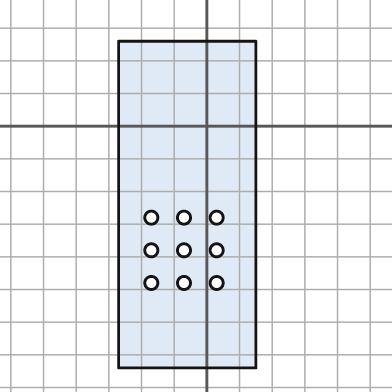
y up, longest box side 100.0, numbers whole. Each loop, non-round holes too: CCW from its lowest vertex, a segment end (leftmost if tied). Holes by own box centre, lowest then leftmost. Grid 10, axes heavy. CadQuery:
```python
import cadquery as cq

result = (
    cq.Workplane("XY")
    .moveTo(-27.0, -74.0)
    .lineTo(15.0, -74.0)
    .lineTo(15.0, 26.0)
    .lineTo(-27.0, 26.0)
    .close()
    .moveTo(-17.0, -48.0)
    .circle(2.0)
    .moveTo(-7.0, -48.0)
    .circle(2.0)
    .moveTo(3.0, -48.0)
    .circle(2.0)
    .moveTo(-17.0, -38.0)
    .circle(2.0)
    .moveTo(-7.0, -38.0)
    .circle(2.0)
    .moveTo(3.0, -38.0)
    .circle(2.0)
    .moveTo(-17.0, -28.0)
    .circle(2.0)
    .moveTo(-7.0, -28.0)
    .circle(2.0)
    .moveTo(3.0, -28.0)
    .circle(2.0)
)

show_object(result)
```